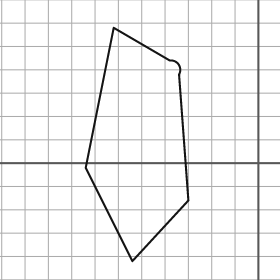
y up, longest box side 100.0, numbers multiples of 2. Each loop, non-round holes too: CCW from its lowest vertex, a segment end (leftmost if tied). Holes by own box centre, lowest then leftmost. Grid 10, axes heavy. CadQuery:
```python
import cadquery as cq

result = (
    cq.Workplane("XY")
    .moveTo(-54.0, -42.0)
    .lineTo(-30.0, -16.0)
    .lineTo(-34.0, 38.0)
    .threePointArc((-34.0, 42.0), (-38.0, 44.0))
    .lineTo(-62.0, 58.0)
    .lineTo(-74.0, -2.0)
    .close()
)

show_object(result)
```